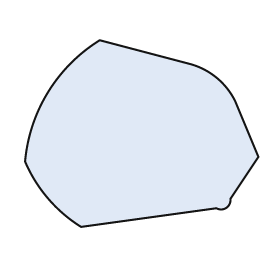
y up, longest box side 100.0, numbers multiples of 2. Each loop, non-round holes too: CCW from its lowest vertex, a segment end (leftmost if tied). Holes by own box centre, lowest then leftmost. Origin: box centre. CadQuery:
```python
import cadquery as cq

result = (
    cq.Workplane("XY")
    .moveTo(-26.0, -40.0)
    .lineTo(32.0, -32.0)
    .threePointArc((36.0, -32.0), (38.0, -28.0))
    .lineTo(50.0, -10.0)
    .lineTo(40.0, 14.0)
    .threePointArc((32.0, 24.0), (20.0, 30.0))
    .lineTo(-18.0, 40.0)
    .threePointArc((-40.0, 18.0), (-50.0, -12.0))
    .threePointArc((-40.0, -28.0), (-26.0, -40.0))
    .close()
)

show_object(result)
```